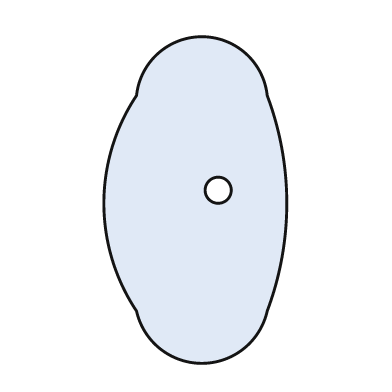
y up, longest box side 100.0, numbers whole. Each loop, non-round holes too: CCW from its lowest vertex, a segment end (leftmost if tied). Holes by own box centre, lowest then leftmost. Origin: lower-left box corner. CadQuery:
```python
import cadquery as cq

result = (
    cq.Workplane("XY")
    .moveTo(10.0, 16.0)
    .threePointArc((30.0, 0.0), (50.0, 16.0))
    .threePointArc((56.0, 49.0), (50.0, 82.0))
    .threePointArc((30.0, 100.0), (10.0, 82.0))
    .threePointArc((0.0, 49.0), (10.0, 16.0))
    .close()
    .moveTo(35.0, 53.0)
    .circle(4.0)
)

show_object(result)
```